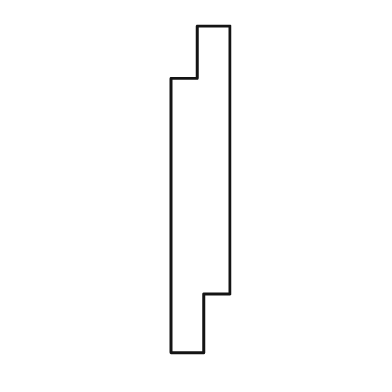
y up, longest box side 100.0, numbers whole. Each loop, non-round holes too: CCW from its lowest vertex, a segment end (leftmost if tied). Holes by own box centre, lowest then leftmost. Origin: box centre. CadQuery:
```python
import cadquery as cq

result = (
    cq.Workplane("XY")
    .moveTo(-9.0, -50.0)
    .lineTo(1.0, -50.0)
    .lineTo(1.0, -32.0)
    .lineTo(9.0, -32.0)
    .lineTo(9.0, 50.0)
    .lineTo(-1.0, 50.0)
    .lineTo(-1.0, 34.0)
    .lineTo(-9.0, 34.0)
    .close()
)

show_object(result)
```